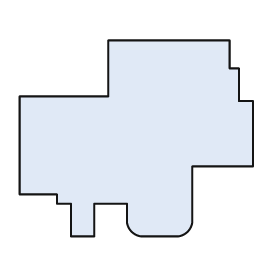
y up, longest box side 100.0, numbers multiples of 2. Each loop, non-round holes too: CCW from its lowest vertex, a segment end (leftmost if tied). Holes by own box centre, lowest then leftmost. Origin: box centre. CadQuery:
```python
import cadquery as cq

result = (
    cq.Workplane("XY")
    .moveTo(-28.0, -42.0)
    .lineTo(-18.0, -42.0)
    .lineTo(-18.0, -28.0)
    .lineTo(-4.0, -28.0)
    .lineTo(-4.0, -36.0)
    .threePointArc((-2.0, -40.0), (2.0, -42.0))
    .lineTo(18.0, -42.0)
    .threePointArc((22.0, -40.0), (24.0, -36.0))
    .lineTo(24.0, -12.0)
    .lineTo(50.0, -12.0)
    .lineTo(50.0, 16.0)
    .lineTo(44.0, 16.0)
    .lineTo(44.0, 30.0)
    .lineTo(40.0, 30.0)
    .lineTo(40.0, 42.0)
    .lineTo(-12.0, 42.0)
    .lineTo(-12.0, 18.0)
    .lineTo(-50.0, 18.0)
    .lineTo(-50.0, -24.0)
    .lineTo(-34.0, -24.0)
    .lineTo(-34.0, -28.0)
    .lineTo(-28.0, -28.0)
    .close()
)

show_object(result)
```